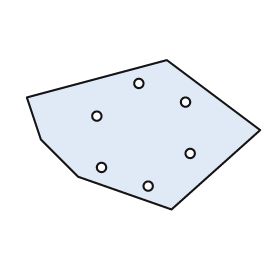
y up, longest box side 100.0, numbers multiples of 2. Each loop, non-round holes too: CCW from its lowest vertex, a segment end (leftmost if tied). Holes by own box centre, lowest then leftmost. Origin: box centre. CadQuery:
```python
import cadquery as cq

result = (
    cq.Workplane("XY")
    .moveTo(12.0, -32.0)
    .lineTo(50.0, 2.0)
    .lineTo(10.0, 32.0)
    .lineTo(-50.0, 16.0)
    .lineTo(-44.0, -2.0)
    .lineTo(-28.0, -18.0)
    .close()
    .moveTo(2.0, -22.0)
    .circle(2.0)
    .moveTo(-18.0, -14.0)
    .circle(2.0)
    .moveTo(20.0, -8.0)
    .circle(2.0)
    .moveTo(-20.0, 8.0)
    .circle(2.0)
    .moveTo(18.0, 14.0)
    .circle(2.0)
    .moveTo(-2.0, 22.0)
    .circle(2.0)
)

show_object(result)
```